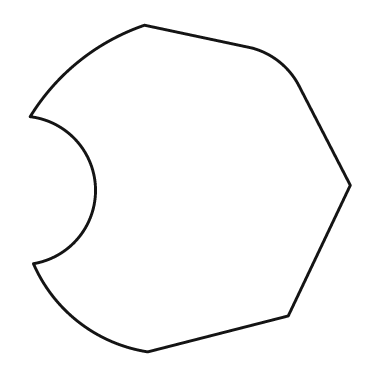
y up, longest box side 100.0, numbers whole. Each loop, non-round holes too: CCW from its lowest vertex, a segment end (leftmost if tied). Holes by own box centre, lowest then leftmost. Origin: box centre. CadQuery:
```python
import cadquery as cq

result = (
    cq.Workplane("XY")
    .moveTo(-13.0, -50.0)
    .lineTo(30.0, -39.0)
    .lineTo(49.0, 1.0)
    .lineTo(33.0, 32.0)
    .threePointArc((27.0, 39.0), (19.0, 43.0))
    .lineTo(-14.0, 50.0)
    .threePointArc((-34.0, 39.0), (-49.0, 22.0))
    .threePointArc((-29.0, 0.0), (-48.0, -23.0))
    .threePointArc((-34.0, -41.0), (-13.0, -50.0))
    .close()
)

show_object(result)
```